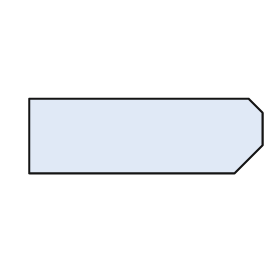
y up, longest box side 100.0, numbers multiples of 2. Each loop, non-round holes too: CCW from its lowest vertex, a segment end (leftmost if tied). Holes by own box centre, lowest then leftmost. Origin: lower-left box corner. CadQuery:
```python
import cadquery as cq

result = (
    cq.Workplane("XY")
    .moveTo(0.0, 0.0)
    .lineTo(88.0, 0.0)
    .lineTo(100.0, 12.0)
    .lineTo(100.0, 26.0)
    .lineTo(94.0, 32.0)
    .lineTo(0.0, 32.0)
    .close()
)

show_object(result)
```